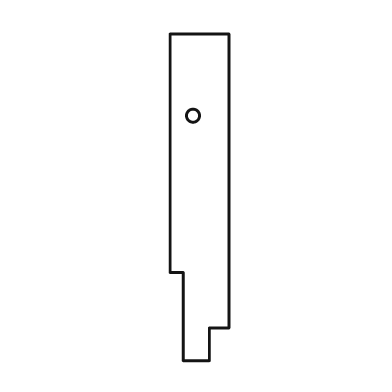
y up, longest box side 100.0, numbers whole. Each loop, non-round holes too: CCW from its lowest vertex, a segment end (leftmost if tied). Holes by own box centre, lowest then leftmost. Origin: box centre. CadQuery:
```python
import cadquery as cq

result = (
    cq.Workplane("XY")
    .moveTo(-5.0, -50.0)
    .lineTo(3.0, -50.0)
    .lineTo(3.0, -40.0)
    .lineTo(9.0, -40.0)
    .lineTo(9.0, 50.0)
    .lineTo(-9.0, 50.0)
    .lineTo(-9.0, -23.0)
    .lineTo(-5.0, -23.0)
    .close()
    .moveTo(-2.0, 25.0)
    .circle(2.0)
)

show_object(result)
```